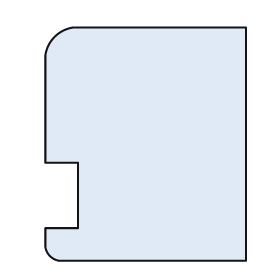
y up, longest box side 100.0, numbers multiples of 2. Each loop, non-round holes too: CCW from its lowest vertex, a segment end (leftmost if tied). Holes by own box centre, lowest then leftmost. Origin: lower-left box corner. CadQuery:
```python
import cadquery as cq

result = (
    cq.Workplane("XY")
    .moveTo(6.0, 0.0)
    .lineTo(86.0, 0.0)
    .lineTo(86.0, 100.0)
    .lineTo(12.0, 100.0)
    .threePointArc((4.0, 96.0), (0.0, 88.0))
    .lineTo(0.0, 42.0)
    .lineTo(14.0, 42.0)
    .lineTo(14.0, 14.0)
    .lineTo(0.0, 14.0)
    .lineTo(0.0, 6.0)
    .threePointArc((2.0, 2.0), (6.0, 0.0))
    .close()
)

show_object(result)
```